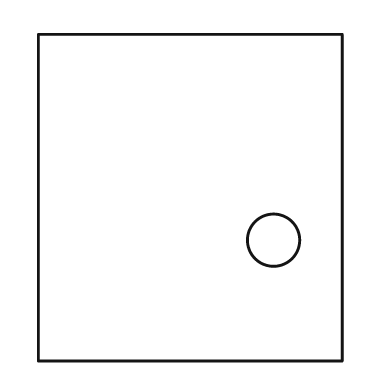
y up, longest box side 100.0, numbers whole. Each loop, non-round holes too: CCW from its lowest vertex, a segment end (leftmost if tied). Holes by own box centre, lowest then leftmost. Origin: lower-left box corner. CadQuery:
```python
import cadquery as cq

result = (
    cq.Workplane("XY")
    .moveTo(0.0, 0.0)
    .lineTo(93.0, 0.0)
    .lineTo(93.0, 100.0)
    .lineTo(0.0, 100.0)
    .close()
    .moveTo(72.0, 37.0)
    .circle(8.0)
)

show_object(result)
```